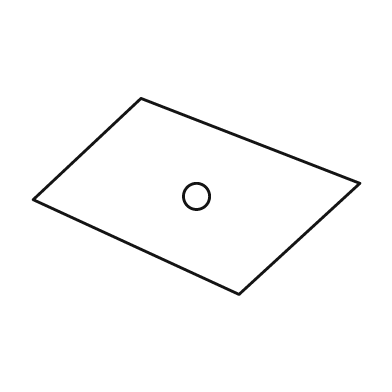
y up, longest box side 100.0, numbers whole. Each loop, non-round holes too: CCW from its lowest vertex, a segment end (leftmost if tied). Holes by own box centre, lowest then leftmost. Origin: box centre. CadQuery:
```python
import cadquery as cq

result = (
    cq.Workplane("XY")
    .moveTo(13.0, -30.0)
    .lineTo(50.0, 4.0)
    .lineTo(-17.0, 30.0)
    .lineTo(-50.0, -1.0)
    .close()
    .moveTo(0.0, 0.0)
    .circle(4.0)
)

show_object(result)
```